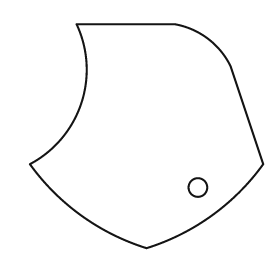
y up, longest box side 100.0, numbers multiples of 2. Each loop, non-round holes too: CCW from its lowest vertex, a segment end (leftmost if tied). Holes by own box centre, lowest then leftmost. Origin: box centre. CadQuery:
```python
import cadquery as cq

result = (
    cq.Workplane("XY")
    .moveTo(0.0, -48.0)
    .threePointArc((28.0, -34.0), (50.0, -12.0))
    .lineTo(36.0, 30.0)
    .threePointArc((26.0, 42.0), (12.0, 48.0))
    .lineTo(-30.0, 48.0)
    .threePointArc((-28.0, 14.0), (-50.0, -12.0))
    .threePointArc((-28.0, -34.0), (0.0, -48.0))
    .close()
    .moveTo(22.0, -22.0)
    .circle(4.0)
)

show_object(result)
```